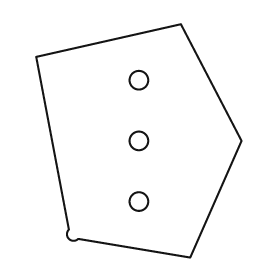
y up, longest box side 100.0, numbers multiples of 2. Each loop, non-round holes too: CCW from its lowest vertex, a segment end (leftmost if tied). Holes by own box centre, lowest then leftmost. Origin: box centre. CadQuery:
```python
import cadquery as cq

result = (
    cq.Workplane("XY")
    .moveTo(22.0, -50.0)
    .lineTo(44.0, 0.0)
    .lineTo(18.0, 50.0)
    .lineTo(-44.0, 36.0)
    .lineTo(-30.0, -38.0)
    .threePointArc((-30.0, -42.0), (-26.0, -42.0))
    .close()
    .moveTo(0.0, -26.0)
    .circle(4.0)
    .moveTo(0.0, 0.0)
    .circle(4.0)
    .moveTo(0.0, 26.0)
    .circle(4.0)
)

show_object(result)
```